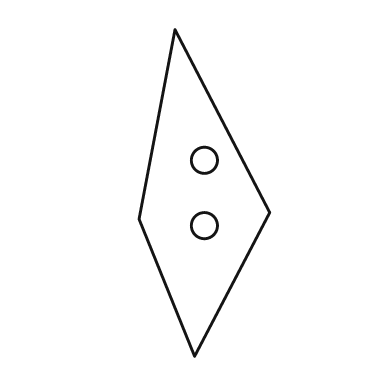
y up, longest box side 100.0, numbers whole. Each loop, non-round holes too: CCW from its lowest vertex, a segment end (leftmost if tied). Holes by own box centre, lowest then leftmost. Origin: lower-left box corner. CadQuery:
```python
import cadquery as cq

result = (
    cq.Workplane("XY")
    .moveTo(17.0, 0.0)
    .lineTo(40.0, 44.0)
    .lineTo(11.0, 100.0)
    .lineTo(0.0, 42.0)
    .close()
    .moveTo(20.0, 40.0)
    .circle(4.0)
    .moveTo(20.0, 60.0)
    .circle(4.0)
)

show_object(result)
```